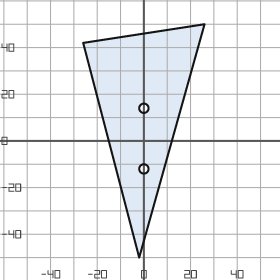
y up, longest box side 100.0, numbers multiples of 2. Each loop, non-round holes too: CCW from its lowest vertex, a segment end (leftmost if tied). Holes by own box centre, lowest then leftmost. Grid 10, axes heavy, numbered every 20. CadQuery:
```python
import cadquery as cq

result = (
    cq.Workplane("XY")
    .moveTo(-2.0, -50.0)
    .lineTo(26.0, 50.0)
    .lineTo(-26.0, 42.0)
    .close()
    .moveTo(0.0, -12.0)
    .circle(2.0)
    .moveTo(0.0, 14.0)
    .circle(2.0)
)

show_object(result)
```